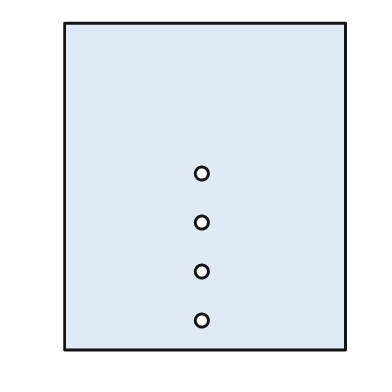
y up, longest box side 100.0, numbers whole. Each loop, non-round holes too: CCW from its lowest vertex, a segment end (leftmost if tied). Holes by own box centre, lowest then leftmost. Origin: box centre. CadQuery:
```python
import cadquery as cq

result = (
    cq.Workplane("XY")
    .moveTo(-43.0, -50.0)
    .lineTo(43.0, -50.0)
    .lineTo(43.0, 50.0)
    .lineTo(-43.0, 50.0)
    .close()
    .moveTo(-1.0, -41.0)
    .circle(2.0)
    .moveTo(-1.0, -26.0)
    .circle(2.0)
    .moveTo(-1.0, -11.0)
    .circle(2.0)
    .moveTo(-1.0, 4.0)
    .circle(2.0)
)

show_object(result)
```